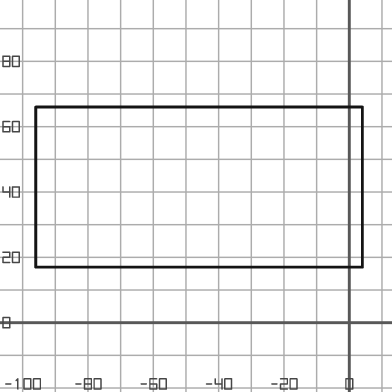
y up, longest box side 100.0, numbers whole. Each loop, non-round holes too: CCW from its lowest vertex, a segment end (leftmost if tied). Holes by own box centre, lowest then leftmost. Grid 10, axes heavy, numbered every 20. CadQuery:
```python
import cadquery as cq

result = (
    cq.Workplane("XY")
    .moveTo(-96.0, 17.0)
    .lineTo(4.0, 17.0)
    .lineTo(4.0, 66.0)
    .lineTo(-96.0, 66.0)
    .close()
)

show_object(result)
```